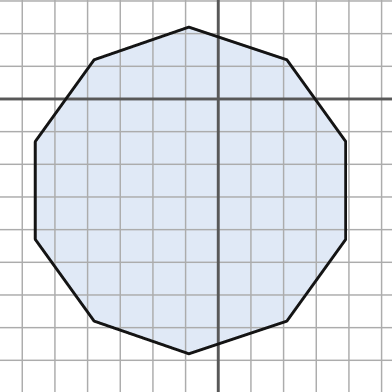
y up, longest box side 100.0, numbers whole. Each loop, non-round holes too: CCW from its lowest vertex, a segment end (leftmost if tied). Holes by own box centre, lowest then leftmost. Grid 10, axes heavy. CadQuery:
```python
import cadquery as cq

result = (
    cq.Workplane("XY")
    .moveTo(-9.0, -78.0)
    .lineTo(21.0, -68.0)
    .lineTo(39.0, -43.0)
    .lineTo(39.0, -13.0)
    .lineTo(21.0, 12.0)
    .lineTo(-9.0, 22.0)
    .lineTo(-38.0, 12.0)
    .lineTo(-56.0, -13.0)
    .lineTo(-56.0, -43.0)
    .lineTo(-38.0, -68.0)
    .close()
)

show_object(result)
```